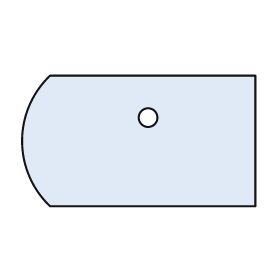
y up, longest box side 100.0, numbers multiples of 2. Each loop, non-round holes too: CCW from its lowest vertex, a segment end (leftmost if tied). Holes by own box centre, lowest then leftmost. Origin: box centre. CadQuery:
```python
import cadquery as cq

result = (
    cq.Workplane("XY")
    .moveTo(-38.0, -28.0)
    .lineTo(50.0, -28.0)
    .lineTo(50.0, 28.0)
    .lineTo(-38.0, 28.0)
    .threePointArc((-50.0, 0.0), (-38.0, -28.0))
    .close()
    .moveTo(4.0, 10.0)
    .circle(4.0)
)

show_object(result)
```